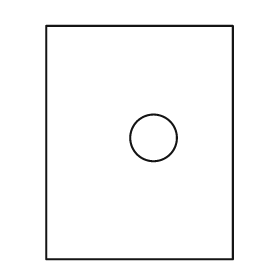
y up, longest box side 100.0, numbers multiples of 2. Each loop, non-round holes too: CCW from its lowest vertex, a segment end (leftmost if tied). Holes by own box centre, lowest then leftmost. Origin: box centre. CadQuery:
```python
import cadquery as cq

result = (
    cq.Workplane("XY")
    .moveTo(-40.0, -50.0)
    .lineTo(40.0, -50.0)
    .lineTo(40.0, 50.0)
    .lineTo(-40.0, 50.0)
    .close()
    .moveTo(6.0, 2.0)
    .circle(10.0)
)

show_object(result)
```